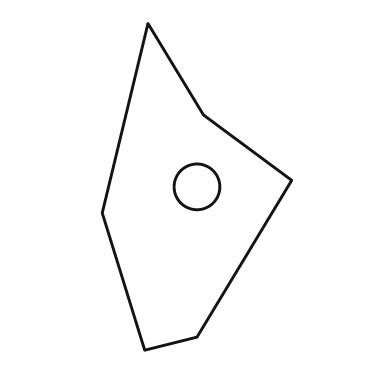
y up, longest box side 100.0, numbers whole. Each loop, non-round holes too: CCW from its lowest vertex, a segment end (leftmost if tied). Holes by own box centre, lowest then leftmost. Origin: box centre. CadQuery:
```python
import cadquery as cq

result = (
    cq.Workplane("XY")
    .moveTo(-16.0, -50.0)
    .lineTo(0.0, -46.0)
    .lineTo(29.0, 2.0)
    .lineTo(2.0, 22.0)
    .lineTo(-15.0, 50.0)
    .lineTo(-29.0, -8.0)
    .close()
    .moveTo(0.0, 0.0)
    .circle(7.0)
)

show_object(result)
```